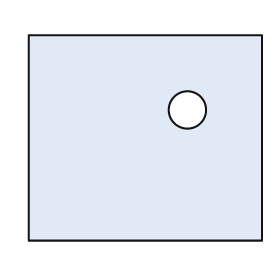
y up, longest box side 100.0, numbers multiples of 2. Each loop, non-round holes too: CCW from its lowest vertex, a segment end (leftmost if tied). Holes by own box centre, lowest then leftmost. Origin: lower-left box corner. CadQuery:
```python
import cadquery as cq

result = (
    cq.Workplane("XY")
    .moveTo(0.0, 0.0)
    .lineTo(100.0, 0.0)
    .lineTo(100.0, 88.0)
    .lineTo(0.0, 88.0)
    .close()
    .moveTo(68.0, 56.0)
    .circle(8.0)
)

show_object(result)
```